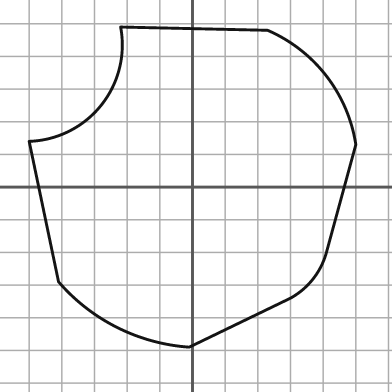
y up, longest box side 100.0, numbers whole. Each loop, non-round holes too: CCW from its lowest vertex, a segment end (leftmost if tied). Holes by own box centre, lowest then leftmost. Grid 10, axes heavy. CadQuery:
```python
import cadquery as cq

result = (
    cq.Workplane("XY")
    .moveTo(-1.0, -49.0)
    .lineTo(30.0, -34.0)
    .threePointArc((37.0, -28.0), (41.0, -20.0))
    .lineTo(50.0, 13.0)
    .threePointArc((41.0, 34.0), (23.0, 48.0))
    .lineTo(-22.0, 49.0)
    .threePointArc((-28.0, 25.0), (-50.0, 14.0))
    .lineTo(-41.0, -29.0)
    .threePointArc((-23.0, -43.0), (-1.0, -49.0))
    .close()
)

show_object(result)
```